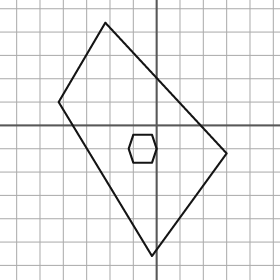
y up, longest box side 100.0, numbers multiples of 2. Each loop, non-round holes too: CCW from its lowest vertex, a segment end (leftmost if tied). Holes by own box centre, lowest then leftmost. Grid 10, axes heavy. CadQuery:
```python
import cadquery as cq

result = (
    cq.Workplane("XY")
    .moveTo(-2.0, -56.0)
    .lineTo(30.0, -12.0)
    .lineTo(-22.0, 44.0)
    .lineTo(-42.0, 10.0)
    .close()
    .moveTo(-10.0, -16.0)
    .lineTo(-2.0, -16.0)
    .lineTo(0.0, -10.0)
    .lineTo(-2.0, -4.0)
    .lineTo(-10.0, -4.0)
    .lineTo(-12.0, -10.0)
    .close()
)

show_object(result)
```